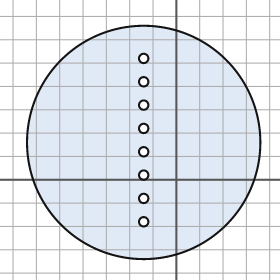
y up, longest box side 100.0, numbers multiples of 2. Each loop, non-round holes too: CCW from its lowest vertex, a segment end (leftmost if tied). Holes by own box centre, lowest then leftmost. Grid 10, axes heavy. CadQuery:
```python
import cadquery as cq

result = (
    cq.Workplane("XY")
    .moveTo(-14.0, 16.0)
    .circle(50.0)
    .moveTo(-14.0, -18.0)
    .circle(2.0)
    .moveTo(-14.0, -8.0)
    .circle(2.0)
    .moveTo(-14.0, 2.0)
    .circle(2.0)
    .moveTo(-14.0, 12.0)
    .circle(2.0)
    .moveTo(-14.0, 22.0)
    .circle(2.0)
    .moveTo(-14.0, 32.0)
    .circle(2.0)
    .moveTo(-14.0, 42.0)
    .circle(2.0)
    .moveTo(-14.0, 52.0)
    .circle(2.0)
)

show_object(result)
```